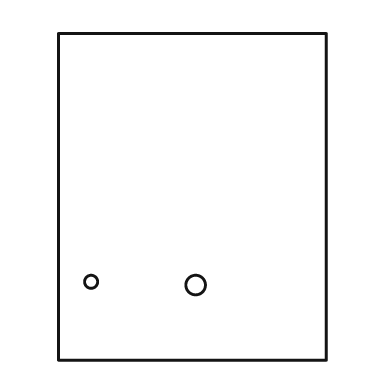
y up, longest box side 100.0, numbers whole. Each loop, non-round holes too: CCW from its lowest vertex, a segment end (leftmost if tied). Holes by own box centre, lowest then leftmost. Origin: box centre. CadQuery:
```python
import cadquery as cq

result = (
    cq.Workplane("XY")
    .moveTo(-41.0, -50.0)
    .lineTo(41.0, -50.0)
    .lineTo(41.0, 50.0)
    .lineTo(-41.0, 50.0)
    .close()
    .moveTo(1.0, -27.0)
    .circle(3.0)
    .moveTo(-31.0, -26.0)
    .circle(2.0)
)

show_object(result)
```